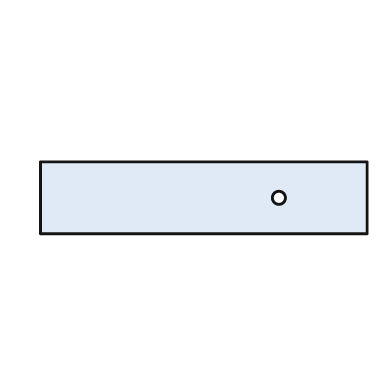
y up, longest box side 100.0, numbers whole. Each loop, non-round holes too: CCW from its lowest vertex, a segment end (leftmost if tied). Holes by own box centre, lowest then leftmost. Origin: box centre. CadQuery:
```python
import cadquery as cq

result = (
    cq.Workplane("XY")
    .moveTo(-50.0, -11.0)
    .lineTo(50.0, -11.0)
    .lineTo(50.0, 11.0)
    .lineTo(-50.0, 11.0)
    .close()
    .moveTo(23.0, 0.0)
    .circle(2.0)
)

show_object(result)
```